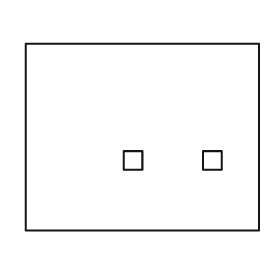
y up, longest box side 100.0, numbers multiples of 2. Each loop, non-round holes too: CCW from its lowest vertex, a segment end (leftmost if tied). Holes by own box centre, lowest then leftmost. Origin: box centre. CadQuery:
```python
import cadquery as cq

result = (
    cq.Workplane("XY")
    .moveTo(-50.0, -40.0)
    .lineTo(50.0, -40.0)
    .lineTo(50.0, 40.0)
    .lineTo(-50.0, 40.0)
    .close()
    .moveTo(-8.0, -14.0)
    .lineTo(0.0, -14.0)
    .lineTo(0.0, -6.0)
    .lineTo(-8.0, -6.0)
    .close()
    .moveTo(26.0, -14.0)
    .lineTo(34.0, -14.0)
    .lineTo(34.0, -6.0)
    .lineTo(26.0, -6.0)
    .close()
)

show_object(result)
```